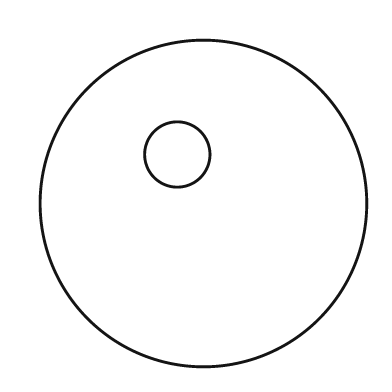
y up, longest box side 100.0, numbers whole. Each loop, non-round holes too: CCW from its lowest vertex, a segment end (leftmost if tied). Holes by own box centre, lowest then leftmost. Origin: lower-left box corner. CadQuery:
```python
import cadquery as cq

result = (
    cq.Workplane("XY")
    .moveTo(50.0, 50.0)
    .circle(50.0)
    .moveTo(42.0, 65.0)
    .circle(10.0)
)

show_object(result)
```